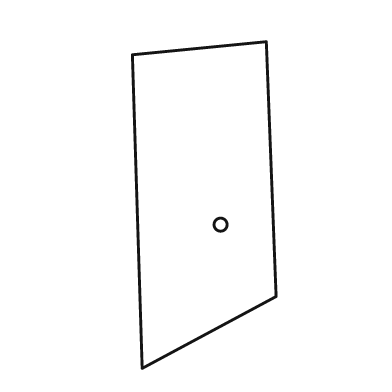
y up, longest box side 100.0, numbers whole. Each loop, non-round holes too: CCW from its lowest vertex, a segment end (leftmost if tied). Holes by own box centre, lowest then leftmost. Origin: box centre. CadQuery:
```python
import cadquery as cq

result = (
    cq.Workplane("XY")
    .moveTo(-19.0, -50.0)
    .lineTo(22.0, -28.0)
    .lineTo(19.0, 50.0)
    .lineTo(-22.0, 46.0)
    .close()
    .moveTo(5.0, -6.0)
    .circle(2.0)
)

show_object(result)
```